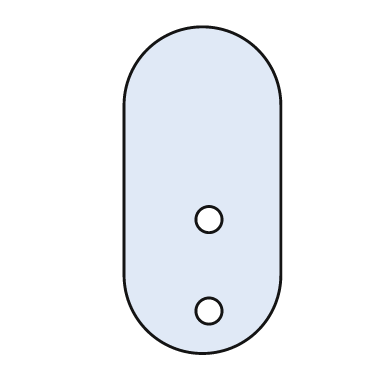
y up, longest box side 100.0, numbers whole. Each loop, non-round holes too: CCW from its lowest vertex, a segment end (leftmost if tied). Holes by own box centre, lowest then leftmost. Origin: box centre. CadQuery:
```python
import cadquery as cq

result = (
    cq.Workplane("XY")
    .moveTo(-24.0, -26.0)
    .threePointArc((0.0, -50.0), (24.0, -26.0))
    .lineTo(24.0, 26.0)
    .threePointArc((0.0, 50.0), (-24.0, 26.0))
    .close()
    .moveTo(2.0, -37.0)
    .circle(4.0)
    .moveTo(2.0, -9.0)
    .circle(4.0)
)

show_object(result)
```